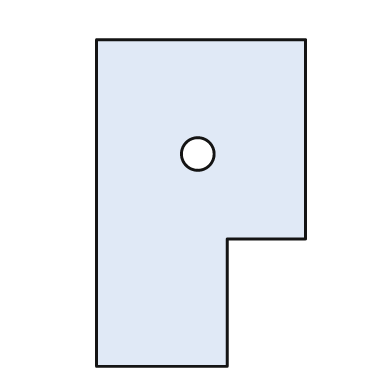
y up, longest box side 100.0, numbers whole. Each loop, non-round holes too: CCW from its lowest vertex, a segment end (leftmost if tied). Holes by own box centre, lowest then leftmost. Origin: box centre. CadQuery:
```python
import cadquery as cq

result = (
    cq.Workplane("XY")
    .moveTo(-32.0, -50.0)
    .lineTo(8.0, -50.0)
    .lineTo(8.0, -11.0)
    .lineTo(32.0, -11.0)
    .lineTo(32.0, 50.0)
    .lineTo(-32.0, 50.0)
    .close()
    .moveTo(-1.0, 15.0)
    .circle(5.0)
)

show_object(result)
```